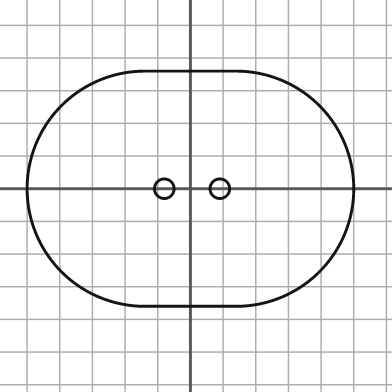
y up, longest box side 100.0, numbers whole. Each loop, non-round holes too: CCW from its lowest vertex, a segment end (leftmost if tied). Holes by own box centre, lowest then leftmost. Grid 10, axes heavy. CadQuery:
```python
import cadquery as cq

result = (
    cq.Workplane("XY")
    .moveTo(-14.0, -36.0)
    .lineTo(14.0, -36.0)
    .threePointArc((50.0, 0.0), (14.0, 36.0))
    .lineTo(-14.0, 36.0)
    .threePointArc((-50.0, 0.0), (-14.0, -36.0))
    .close()
    .moveTo(-8.0, 0.0)
    .circle(3.0)
    .moveTo(9.0, 0.0)
    .circle(3.0)
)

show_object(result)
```